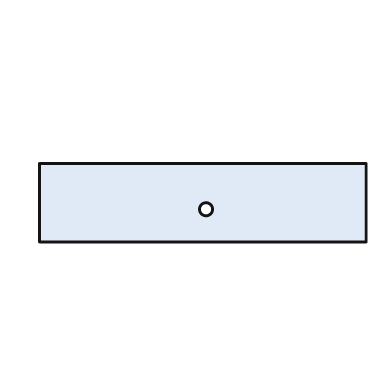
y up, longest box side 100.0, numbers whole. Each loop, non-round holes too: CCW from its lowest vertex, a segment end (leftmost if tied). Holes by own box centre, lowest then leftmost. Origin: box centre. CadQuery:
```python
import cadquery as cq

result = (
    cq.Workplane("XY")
    .moveTo(-50.0, -12.0)
    .lineTo(50.0, -12.0)
    .lineTo(50.0, 12.0)
    .lineTo(-50.0, 12.0)
    .close()
    .moveTo(1.0, -2.0)
    .circle(2.0)
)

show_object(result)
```